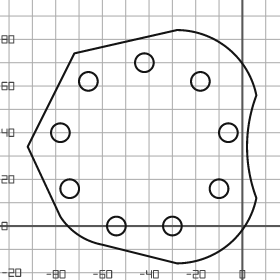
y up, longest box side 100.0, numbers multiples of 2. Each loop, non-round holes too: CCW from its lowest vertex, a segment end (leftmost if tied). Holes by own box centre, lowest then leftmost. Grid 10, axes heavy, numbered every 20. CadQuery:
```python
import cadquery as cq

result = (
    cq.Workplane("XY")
    .moveTo(-28.0, -16.0)
    .threePointArc((-6.0, -8.0), (6.0, 12.0))
    .threePointArc((2.0, 34.0), (6.0, 56.0))
    .threePointArc((-6.0, 76.0), (-28.0, 84.0))
    .lineTo(-72.0, 74.0)
    .lineTo(-92.0, 34.0)
    .lineTo(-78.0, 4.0)
    .threePointArc((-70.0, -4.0), (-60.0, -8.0))
    .close()
    .moveTo(-54.0, 0.0)
    .circle(4.0)
    .moveTo(-30.0, 0.0)
    .circle(4.0)
    .moveTo(-74.0, 16.0)
    .circle(4.0)
    .moveTo(-10.0, 16.0)
    .circle(4.0)
    .moveTo(-78.0, 40.0)
    .circle(4.0)
    .moveTo(-6.0, 40.0)
    .circle(4.0)
    .moveTo(-66.0, 62.0)
    .circle(4.0)
    .moveTo(-18.0, 62.0)
    .circle(4.0)
    .moveTo(-42.0, 70.0)
    .circle(4.0)
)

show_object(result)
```